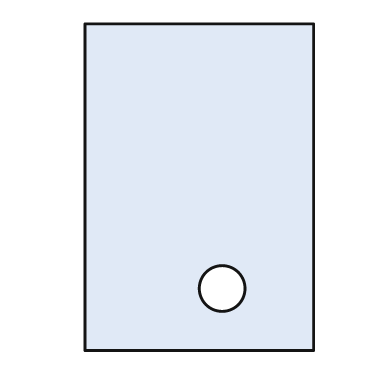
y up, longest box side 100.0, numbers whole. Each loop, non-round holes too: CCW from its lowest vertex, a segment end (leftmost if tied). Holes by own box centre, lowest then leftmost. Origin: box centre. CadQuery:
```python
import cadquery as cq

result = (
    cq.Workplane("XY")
    .moveTo(-35.0, -50.0)
    .lineTo(35.0, -50.0)
    .lineTo(35.0, 50.0)
    .lineTo(-35.0, 50.0)
    .close()
    .moveTo(7.0, -31.0)
    .circle(7.0)
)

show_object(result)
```